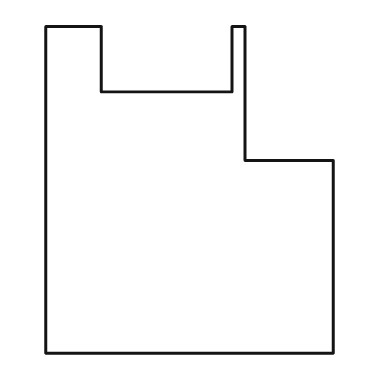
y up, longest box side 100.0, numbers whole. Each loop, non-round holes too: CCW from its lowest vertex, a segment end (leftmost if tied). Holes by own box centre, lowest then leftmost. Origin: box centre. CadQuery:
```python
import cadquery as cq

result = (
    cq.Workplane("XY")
    .moveTo(-44.0, -50.0)
    .lineTo(44.0, -50.0)
    .lineTo(44.0, 9.0)
    .lineTo(17.0, 9.0)
    .lineTo(17.0, 50.0)
    .lineTo(13.0, 50.0)
    .lineTo(13.0, 30.0)
    .lineTo(-27.0, 30.0)
    .lineTo(-27.0, 50.0)
    .lineTo(-44.0, 50.0)
    .close()
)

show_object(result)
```